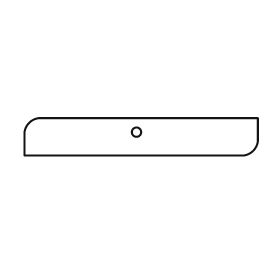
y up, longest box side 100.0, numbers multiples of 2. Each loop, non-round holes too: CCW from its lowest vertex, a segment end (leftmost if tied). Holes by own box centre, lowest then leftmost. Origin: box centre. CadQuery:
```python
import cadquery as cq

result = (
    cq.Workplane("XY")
    .moveTo(-50.0, -8.0)
    .lineTo(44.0, -8.0)
    .threePointArc((48.0, -6.0), (50.0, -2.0))
    .lineTo(50.0, 8.0)
    .lineTo(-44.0, 8.0)
    .threePointArc((-48.0, 6.0), (-50.0, 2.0))
    .close()
    .moveTo(-2.0, 2.0)
    .circle(2.0)
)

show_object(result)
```